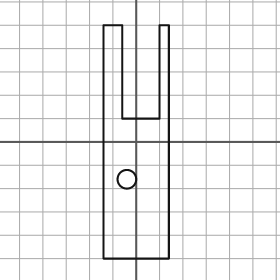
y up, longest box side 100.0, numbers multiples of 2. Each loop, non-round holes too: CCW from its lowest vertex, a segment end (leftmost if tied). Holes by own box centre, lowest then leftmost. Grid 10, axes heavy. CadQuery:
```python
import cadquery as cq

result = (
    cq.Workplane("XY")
    .moveTo(-14.0, -50.0)
    .lineTo(14.0, -50.0)
    .lineTo(14.0, 50.0)
    .lineTo(10.0, 50.0)
    .lineTo(10.0, 10.0)
    .lineTo(-6.0, 10.0)
    .lineTo(-6.0, 50.0)
    .lineTo(-14.0, 50.0)
    .close()
    .moveTo(-4.0, -16.0)
    .circle(4.0)
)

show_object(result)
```